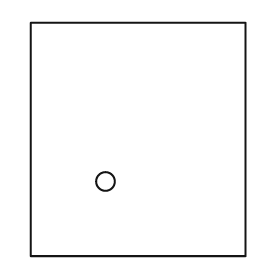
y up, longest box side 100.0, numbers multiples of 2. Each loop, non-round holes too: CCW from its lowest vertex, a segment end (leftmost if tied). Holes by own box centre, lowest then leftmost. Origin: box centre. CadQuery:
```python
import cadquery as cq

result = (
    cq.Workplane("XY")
    .moveTo(-46.0, -50.0)
    .lineTo(46.0, -50.0)
    .lineTo(46.0, 50.0)
    .lineTo(-46.0, 50.0)
    .close()
    .moveTo(-14.0, -18.0)
    .circle(4.0)
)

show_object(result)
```